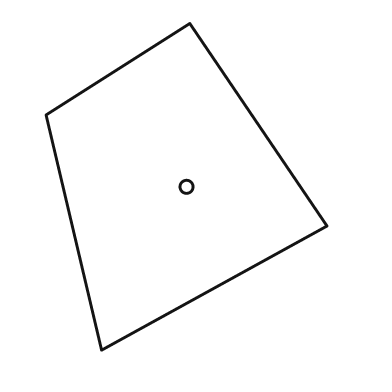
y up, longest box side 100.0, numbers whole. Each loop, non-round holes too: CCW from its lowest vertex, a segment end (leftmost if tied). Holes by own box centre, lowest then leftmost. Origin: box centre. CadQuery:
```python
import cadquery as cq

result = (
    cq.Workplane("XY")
    .moveTo(-26.0, -50.0)
    .lineTo(43.0, -12.0)
    .lineTo(1.0, 50.0)
    .lineTo(-43.0, 22.0)
    .close()
    .moveTo(0.0, 0.0)
    .circle(2.0)
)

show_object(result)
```